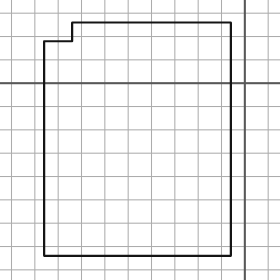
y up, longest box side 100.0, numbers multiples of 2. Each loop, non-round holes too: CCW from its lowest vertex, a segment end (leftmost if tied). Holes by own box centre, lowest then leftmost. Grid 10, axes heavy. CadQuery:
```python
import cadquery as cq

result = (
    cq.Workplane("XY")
    .moveTo(-86.0, -74.0)
    .lineTo(-6.0, -74.0)
    .lineTo(-6.0, 26.0)
    .lineTo(-74.0, 26.0)
    .lineTo(-74.0, 18.0)
    .lineTo(-86.0, 18.0)
    .close()
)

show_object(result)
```